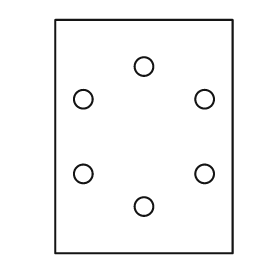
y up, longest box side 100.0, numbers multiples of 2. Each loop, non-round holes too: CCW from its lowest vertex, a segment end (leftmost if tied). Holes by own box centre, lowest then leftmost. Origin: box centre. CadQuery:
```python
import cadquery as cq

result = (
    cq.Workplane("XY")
    .moveTo(-38.0, -50.0)
    .lineTo(38.0, -50.0)
    .lineTo(38.0, 50.0)
    .lineTo(-38.0, 50.0)
    .close()
    .moveTo(0.0, -30.0)
    .circle(4.0)
    .moveTo(-26.0, -16.0)
    .circle(4.0)
    .moveTo(26.0, -16.0)
    .circle(4.0)
    .moveTo(-26.0, 16.0)
    .circle(4.0)
    .moveTo(26.0, 16.0)
    .circle(4.0)
    .moveTo(0.0, 30.0)
    .circle(4.0)
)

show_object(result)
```